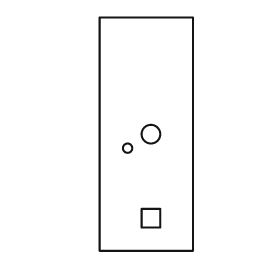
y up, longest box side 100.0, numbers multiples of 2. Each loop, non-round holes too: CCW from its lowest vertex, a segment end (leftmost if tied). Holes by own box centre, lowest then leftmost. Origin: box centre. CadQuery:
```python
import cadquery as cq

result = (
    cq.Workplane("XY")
    .moveTo(-20.0, -50.0)
    .lineTo(20.0, -50.0)
    .lineTo(20.0, 50.0)
    .lineTo(-20.0, 50.0)
    .close()
    .moveTo(-2.0, -40.0)
    .lineTo(6.0, -40.0)
    .lineTo(6.0, -32.0)
    .lineTo(-2.0, -32.0)
    .close()
    .moveTo(-8.0, -6.0)
    .circle(2.0)
    .moveTo(2.0, 0.0)
    .circle(4.0)
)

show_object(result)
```